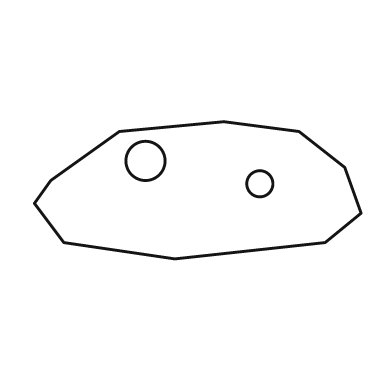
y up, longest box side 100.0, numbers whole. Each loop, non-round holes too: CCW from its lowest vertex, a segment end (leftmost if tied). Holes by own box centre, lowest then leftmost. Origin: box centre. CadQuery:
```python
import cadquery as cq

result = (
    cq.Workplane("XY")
    .moveTo(-7.0, -21.0)
    .lineTo(39.0, -16.0)
    .lineTo(50.0, -7.0)
    .lineTo(45.0, 7.0)
    .lineTo(31.0, 18.0)
    .lineTo(8.0, 21.0)
    .lineTo(-24.0, 18.0)
    .lineTo(-45.0, 3.0)
    .lineTo(-50.0, -4.0)
    .lineTo(-41.0, -16.0)
    .close()
    .moveTo(19.0, 2.0)
    .circle(4.0)
    .moveTo(-16.0, 9.0)
    .circle(6.0)
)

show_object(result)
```